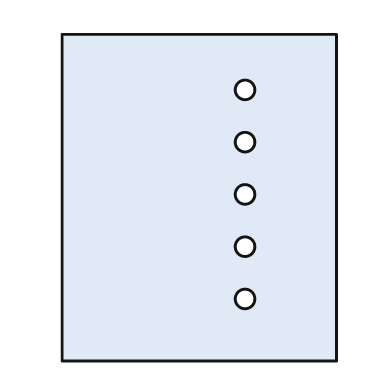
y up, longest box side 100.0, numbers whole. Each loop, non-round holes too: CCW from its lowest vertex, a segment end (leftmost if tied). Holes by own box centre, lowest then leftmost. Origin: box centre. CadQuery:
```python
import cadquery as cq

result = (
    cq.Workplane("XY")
    .moveTo(-42.0, -50.0)
    .lineTo(42.0, -50.0)
    .lineTo(42.0, 50.0)
    .lineTo(-42.0, 50.0)
    .close()
    .moveTo(14.0, -31.0)
    .circle(3.0)
    .moveTo(14.0, -15.0)
    .circle(3.0)
    .moveTo(14.0, 1.0)
    .circle(3.0)
    .moveTo(14.0, 17.0)
    .circle(3.0)
    .moveTo(14.0, 33.0)
    .circle(3.0)
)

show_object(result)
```